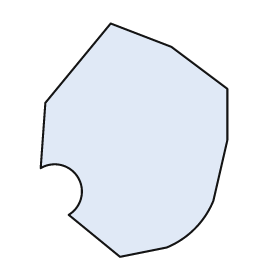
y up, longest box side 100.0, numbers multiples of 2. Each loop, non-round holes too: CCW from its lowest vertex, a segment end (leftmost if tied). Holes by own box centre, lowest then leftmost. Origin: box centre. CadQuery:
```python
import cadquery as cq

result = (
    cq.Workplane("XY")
    .moveTo(-6.0, -50.0)
    .lineTo(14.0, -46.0)
    .threePointArc((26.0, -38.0), (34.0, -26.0))
    .lineTo(40.0, 0.0)
    .lineTo(40.0, 22.0)
    .lineTo(16.0, 40.0)
    .lineTo(-10.0, 50.0)
    .lineTo(-38.0, 16.0)
    .lineTo(-40.0, -12.0)
    .threePointArc((-24.0, -16.0), (-28.0, -32.0))
    .close()
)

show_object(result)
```